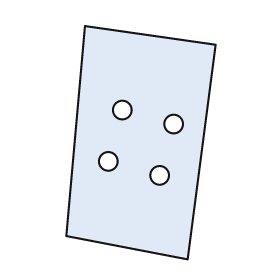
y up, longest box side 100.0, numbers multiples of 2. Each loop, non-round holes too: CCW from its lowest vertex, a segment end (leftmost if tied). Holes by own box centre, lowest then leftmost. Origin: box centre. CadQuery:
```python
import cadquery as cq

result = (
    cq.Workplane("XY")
    .moveTo(20.0, -50.0)
    .lineTo(32.0, 42.0)
    .lineTo(-24.0, 50.0)
    .lineTo(-32.0, -40.0)
    .close()
    .moveTo(8.0, -14.0)
    .circle(4.0)
    .moveTo(-14.0, -8.0)
    .circle(4.0)
    .moveTo(14.0, 8.0)
    .circle(4.0)
    .moveTo(-8.0, 14.0)
    .circle(4.0)
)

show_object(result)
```